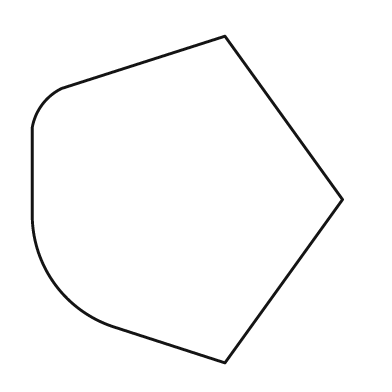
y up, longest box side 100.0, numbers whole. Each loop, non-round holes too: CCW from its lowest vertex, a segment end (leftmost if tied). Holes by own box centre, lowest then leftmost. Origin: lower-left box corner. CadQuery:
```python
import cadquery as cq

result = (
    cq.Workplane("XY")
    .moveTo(59.0, 0.0)
    .lineTo(95.0, 50.0)
    .lineTo(59.0, 100.0)
    .lineTo(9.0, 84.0)
    .threePointArc((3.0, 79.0), (0.0, 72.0))
    .lineTo(0.0, 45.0)
    .threePointArc((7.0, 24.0), (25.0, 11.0))
    .close()
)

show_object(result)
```